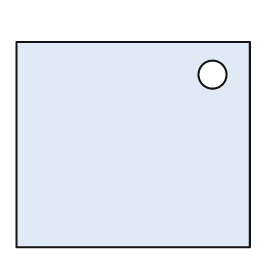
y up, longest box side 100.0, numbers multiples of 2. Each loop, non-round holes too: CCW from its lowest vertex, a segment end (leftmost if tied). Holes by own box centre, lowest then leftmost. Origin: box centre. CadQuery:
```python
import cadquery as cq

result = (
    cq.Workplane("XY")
    .moveTo(-50.0, -44.0)
    .lineTo(50.0, -44.0)
    .lineTo(50.0, 44.0)
    .lineTo(-50.0, 44.0)
    .close()
    .moveTo(34.0, 30.0)
    .circle(6.0)
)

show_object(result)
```